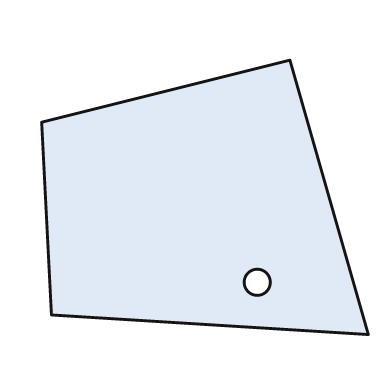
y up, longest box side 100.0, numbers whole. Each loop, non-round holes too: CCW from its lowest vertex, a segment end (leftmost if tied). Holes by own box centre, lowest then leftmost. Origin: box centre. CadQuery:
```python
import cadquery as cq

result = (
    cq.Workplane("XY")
    .moveTo(50.0, -42.0)
    .lineTo(26.0, 42.0)
    .lineTo(-50.0, 23.0)
    .lineTo(-47.0, -36.0)
    .close()
    .moveTo(16.0, -26.0)
    .circle(4.0)
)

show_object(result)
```